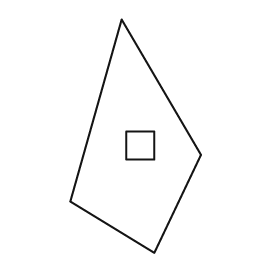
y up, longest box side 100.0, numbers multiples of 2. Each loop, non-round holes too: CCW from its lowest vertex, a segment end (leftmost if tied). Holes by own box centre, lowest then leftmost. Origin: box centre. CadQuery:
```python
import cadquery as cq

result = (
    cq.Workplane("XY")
    .moveTo(8.0, -50.0)
    .lineTo(28.0, -8.0)
    .lineTo(-6.0, 50.0)
    .lineTo(-28.0, -28.0)
    .close()
    .moveTo(-4.0, -10.0)
    .lineTo(8.0, -10.0)
    .lineTo(8.0, 2.0)
    .lineTo(-4.0, 2.0)
    .close()
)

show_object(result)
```